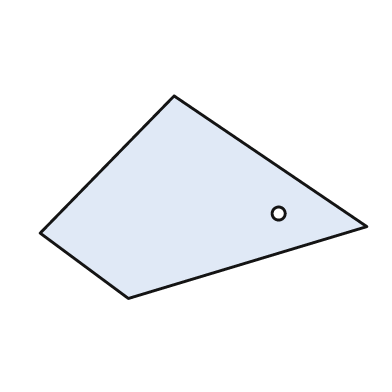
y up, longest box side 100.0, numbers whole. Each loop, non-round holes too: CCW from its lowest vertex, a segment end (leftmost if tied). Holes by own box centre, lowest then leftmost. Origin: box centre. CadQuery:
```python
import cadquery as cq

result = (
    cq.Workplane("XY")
    .moveTo(-23.0, -31.0)
    .lineTo(50.0, -9.0)
    .lineTo(-9.0, 31.0)
    .lineTo(-50.0, -11.0)
    .close()
    .moveTo(23.0, -5.0)
    .circle(2.0)
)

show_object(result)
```